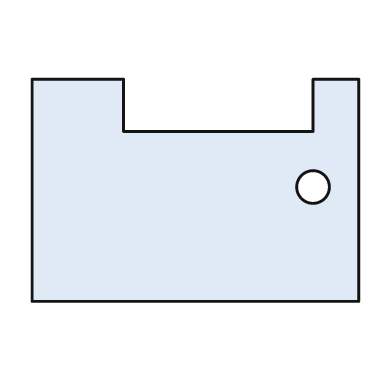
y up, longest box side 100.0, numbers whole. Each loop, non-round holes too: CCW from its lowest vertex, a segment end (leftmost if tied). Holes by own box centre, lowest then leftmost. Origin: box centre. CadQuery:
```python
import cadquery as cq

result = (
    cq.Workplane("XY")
    .moveTo(-50.0, -34.0)
    .lineTo(50.0, -34.0)
    .lineTo(50.0, 34.0)
    .lineTo(36.0, 34.0)
    .lineTo(36.0, 18.0)
    .lineTo(-22.0, 18.0)
    .lineTo(-22.0, 34.0)
    .lineTo(-50.0, 34.0)
    .close()
    .moveTo(36.0, 1.0)
    .circle(5.0)
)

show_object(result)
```